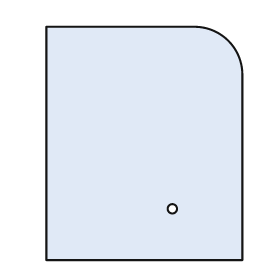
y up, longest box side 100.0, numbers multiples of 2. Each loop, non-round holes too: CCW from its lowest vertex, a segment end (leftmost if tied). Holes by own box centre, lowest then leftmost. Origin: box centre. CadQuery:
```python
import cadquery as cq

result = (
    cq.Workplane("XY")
    .moveTo(-42.0, -50.0)
    .lineTo(42.0, -50.0)
    .lineTo(42.0, 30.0)
    .threePointArc((36.0, 44.0), (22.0, 50.0))
    .lineTo(-42.0, 50.0)
    .close()
    .moveTo(12.0, -28.0)
    .circle(2.0)
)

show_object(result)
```